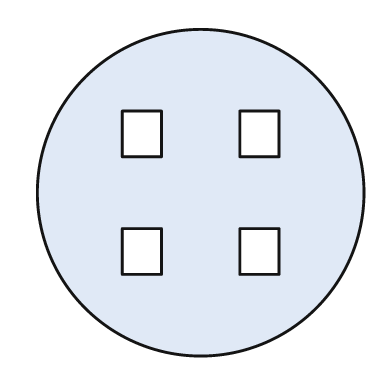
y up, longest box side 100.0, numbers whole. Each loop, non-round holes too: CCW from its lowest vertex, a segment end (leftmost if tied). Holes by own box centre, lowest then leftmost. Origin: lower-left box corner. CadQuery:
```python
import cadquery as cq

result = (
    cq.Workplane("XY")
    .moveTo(50.0, 50.0)
    .circle(50.0)
    .moveTo(26.0, 25.0)
    .lineTo(38.0, 25.0)
    .lineTo(38.0, 39.0)
    .lineTo(26.0, 39.0)
    .close()
    .moveTo(62.0, 25.0)
    .lineTo(74.0, 25.0)
    .lineTo(74.0, 39.0)
    .lineTo(62.0, 39.0)
    .close()
    .moveTo(26.0, 61.0)
    .lineTo(38.0, 61.0)
    .lineTo(38.0, 75.0)
    .lineTo(26.0, 75.0)
    .close()
    .moveTo(62.0, 61.0)
    .lineTo(74.0, 61.0)
    .lineTo(74.0, 75.0)
    .lineTo(62.0, 75.0)
    .close()
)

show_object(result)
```